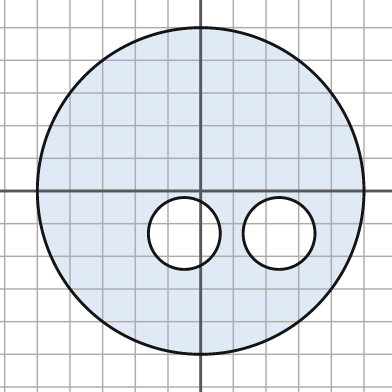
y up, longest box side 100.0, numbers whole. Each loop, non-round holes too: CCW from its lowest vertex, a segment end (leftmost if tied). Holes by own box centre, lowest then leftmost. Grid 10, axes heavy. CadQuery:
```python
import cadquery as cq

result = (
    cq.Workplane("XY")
    .moveTo(0.0, 0.0)
    .circle(50.0)
    .moveTo(-5.0, -13.0)
    .circle(11.0)
    .moveTo(24.0, -13.0)
    .circle(11.0)
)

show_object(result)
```